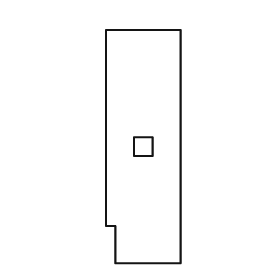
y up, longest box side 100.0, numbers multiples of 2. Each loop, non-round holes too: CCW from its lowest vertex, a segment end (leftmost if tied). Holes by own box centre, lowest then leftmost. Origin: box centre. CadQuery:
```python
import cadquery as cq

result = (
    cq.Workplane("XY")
    .moveTo(-12.0, -50.0)
    .lineTo(16.0, -50.0)
    .lineTo(16.0, 50.0)
    .lineTo(-16.0, 50.0)
    .lineTo(-16.0, -34.0)
    .lineTo(-12.0, -34.0)
    .close()
    .moveTo(-4.0, -4.0)
    .lineTo(4.0, -4.0)
    .lineTo(4.0, 4.0)
    .lineTo(-4.0, 4.0)
    .close()
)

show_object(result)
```